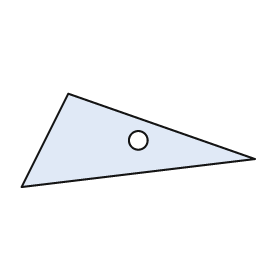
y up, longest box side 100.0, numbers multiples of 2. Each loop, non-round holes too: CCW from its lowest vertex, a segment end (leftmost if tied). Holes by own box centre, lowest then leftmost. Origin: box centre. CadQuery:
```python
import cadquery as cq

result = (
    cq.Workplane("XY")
    .moveTo(-50.0, -20.0)
    .lineTo(50.0, -8.0)
    .lineTo(-30.0, 20.0)
    .close()
    .moveTo(0.0, 0.0)
    .circle(4.0)
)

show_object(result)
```